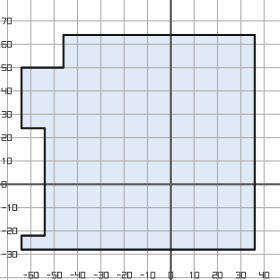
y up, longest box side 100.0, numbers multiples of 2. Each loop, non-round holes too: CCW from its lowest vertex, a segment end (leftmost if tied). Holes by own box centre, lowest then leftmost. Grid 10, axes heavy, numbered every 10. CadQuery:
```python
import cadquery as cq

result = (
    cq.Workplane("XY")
    .moveTo(-64.0, -28.0)
    .lineTo(36.0, -28.0)
    .lineTo(36.0, 64.0)
    .lineTo(-46.0, 64.0)
    .lineTo(-46.0, 50.0)
    .lineTo(-64.0, 50.0)
    .lineTo(-64.0, 24.0)
    .lineTo(-54.0, 24.0)
    .lineTo(-54.0, -22.0)
    .lineTo(-64.0, -22.0)
    .close()
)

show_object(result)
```